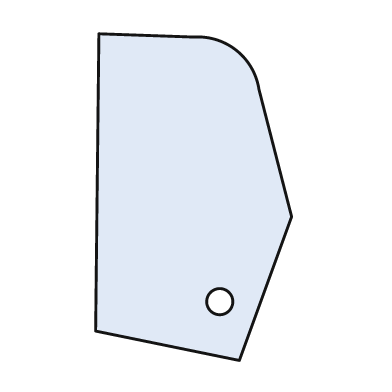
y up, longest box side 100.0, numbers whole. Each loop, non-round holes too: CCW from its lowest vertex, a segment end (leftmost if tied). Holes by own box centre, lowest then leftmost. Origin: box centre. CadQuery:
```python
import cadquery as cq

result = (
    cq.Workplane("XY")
    .moveTo(14.0, -50.0)
    .lineTo(30.0, -6.0)
    .lineTo(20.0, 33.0)
    .threePointArc((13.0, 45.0), (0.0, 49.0))
    .lineTo(-29.0, 50.0)
    .lineTo(-30.0, -41.0)
    .close()
    .moveTo(8.0, -32.0)
    .circle(4.0)
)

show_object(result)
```